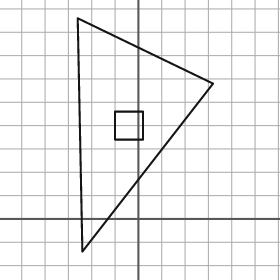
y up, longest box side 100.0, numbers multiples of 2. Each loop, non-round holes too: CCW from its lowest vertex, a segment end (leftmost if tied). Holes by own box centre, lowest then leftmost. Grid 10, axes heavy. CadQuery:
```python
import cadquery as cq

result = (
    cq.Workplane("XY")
    .moveTo(-24.0, -14.0)
    .lineTo(32.0, 58.0)
    .lineTo(-26.0, 86.0)
    .close()
    .moveTo(-10.0, 34.0)
    .lineTo(2.0, 34.0)
    .lineTo(2.0, 46.0)
    .lineTo(-10.0, 46.0)
    .close()
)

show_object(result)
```